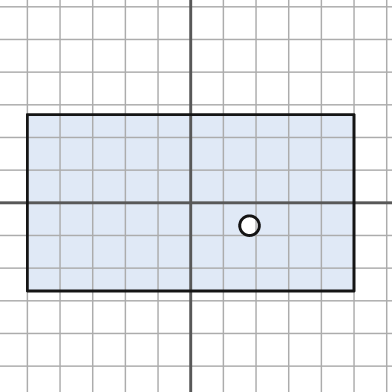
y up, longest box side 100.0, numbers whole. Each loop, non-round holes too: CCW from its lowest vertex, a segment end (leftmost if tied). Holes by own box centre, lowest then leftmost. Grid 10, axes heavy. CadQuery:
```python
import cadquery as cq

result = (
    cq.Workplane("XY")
    .moveTo(-50.0, -27.0)
    .lineTo(50.0, -27.0)
    .lineTo(50.0, 27.0)
    .lineTo(-50.0, 27.0)
    .close()
    .moveTo(18.0, -7.0)
    .circle(3.0)
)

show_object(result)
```